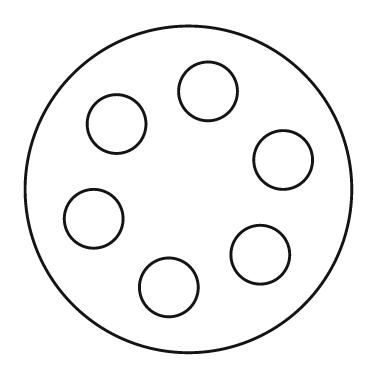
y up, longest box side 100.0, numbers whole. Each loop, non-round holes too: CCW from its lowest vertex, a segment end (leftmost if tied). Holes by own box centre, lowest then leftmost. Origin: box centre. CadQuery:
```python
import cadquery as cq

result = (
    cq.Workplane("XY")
    .moveTo(0.0, 0.0)
    .circle(50.0)
    .moveTo(-6.0, -30.0)
    .circle(9.0)
    .moveTo(22.0, -20.0)
    .circle(9.0)
    .moveTo(-29.0, -9.0)
    .circle(9.0)
    .moveTo(29.0, 9.0)
    .circle(9.0)
    .moveTo(-22.0, 20.0)
    .circle(9.0)
    .moveTo(6.0, 30.0)
    .circle(9.0)
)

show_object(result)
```